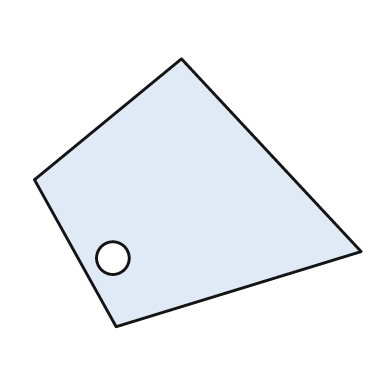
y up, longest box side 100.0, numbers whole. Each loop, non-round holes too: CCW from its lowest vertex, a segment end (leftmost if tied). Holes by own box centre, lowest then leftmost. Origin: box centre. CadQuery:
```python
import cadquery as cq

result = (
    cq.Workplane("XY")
    .moveTo(-25.0, -41.0)
    .lineTo(50.0, -18.0)
    .lineTo(-5.0, 41.0)
    .lineTo(-50.0, 4.0)
    .close()
    .moveTo(-26.0, -20.0)
    .circle(5.0)
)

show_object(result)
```